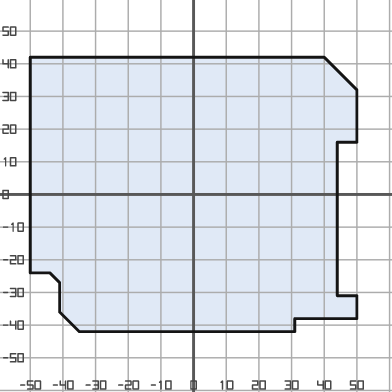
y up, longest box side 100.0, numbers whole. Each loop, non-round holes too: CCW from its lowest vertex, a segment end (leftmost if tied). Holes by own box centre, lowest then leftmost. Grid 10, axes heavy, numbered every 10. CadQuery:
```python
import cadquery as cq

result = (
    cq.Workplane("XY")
    .moveTo(-35.0, -42.0)
    .lineTo(31.0, -42.0)
    .lineTo(31.0, -38.0)
    .lineTo(50.0, -38.0)
    .lineTo(50.0, -31.0)
    .lineTo(44.0, -31.0)
    .lineTo(44.0, 16.0)
    .lineTo(50.0, 16.0)
    .lineTo(50.0, 32.0)
    .lineTo(40.0, 42.0)
    .lineTo(-50.0, 42.0)
    .lineTo(-50.0, -24.0)
    .lineTo(-44.0, -24.0)
    .lineTo(-41.0, -27.0)
    .lineTo(-41.0, -36.0)
    .close()
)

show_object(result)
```